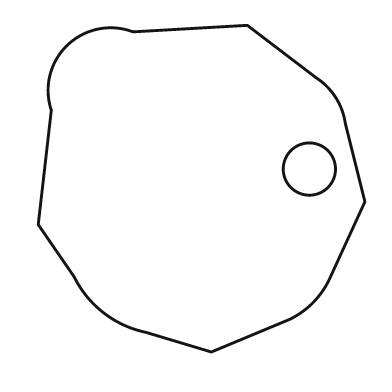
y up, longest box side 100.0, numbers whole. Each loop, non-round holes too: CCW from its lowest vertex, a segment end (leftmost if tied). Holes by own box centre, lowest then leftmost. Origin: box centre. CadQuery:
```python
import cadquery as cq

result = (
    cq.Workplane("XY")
    .moveTo(3.0, -50.0)
    .lineTo(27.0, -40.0)
    .threePointArc((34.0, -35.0), (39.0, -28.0))
    .lineTo(50.0, -4.0)
    .lineTo(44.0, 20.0)
    .threePointArc((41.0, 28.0), (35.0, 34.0))
    .lineTo(14.0, 50.0)
    .lineTo(-21.0, 48.0)
    .threePointArc((-41.0, 44.0), (-46.0, 24.0))
    .lineTo(-50.0, -11.0)
    .lineTo(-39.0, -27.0)
    .threePointArc((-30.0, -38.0), (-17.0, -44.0))
    .close()
    .moveTo(33.0, 6.0)
    .circle(8.0)
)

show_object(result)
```